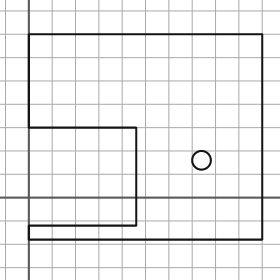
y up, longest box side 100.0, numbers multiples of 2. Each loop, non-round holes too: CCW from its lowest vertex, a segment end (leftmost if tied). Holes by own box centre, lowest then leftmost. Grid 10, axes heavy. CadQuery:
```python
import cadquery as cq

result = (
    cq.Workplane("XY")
    .moveTo(0.0, -18.0)
    .lineTo(100.0, -18.0)
    .lineTo(100.0, 70.0)
    .lineTo(0.0, 70.0)
    .lineTo(0.0, 30.0)
    .lineTo(46.0, 30.0)
    .lineTo(46.0, -12.0)
    .lineTo(0.0, -12.0)
    .close()
    .moveTo(74.0, 16.0)
    .circle(4.0)
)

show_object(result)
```